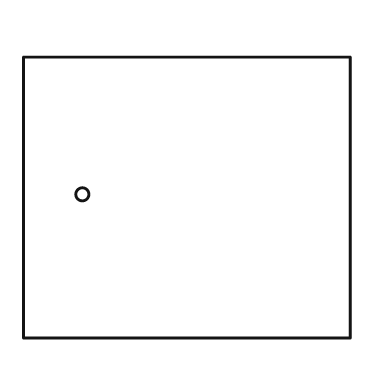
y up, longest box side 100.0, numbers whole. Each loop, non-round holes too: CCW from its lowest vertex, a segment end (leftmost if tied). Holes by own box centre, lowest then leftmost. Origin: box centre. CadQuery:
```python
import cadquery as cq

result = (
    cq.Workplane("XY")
    .moveTo(-50.0, -43.0)
    .lineTo(50.0, -43.0)
    .lineTo(50.0, 43.0)
    .lineTo(-50.0, 43.0)
    .close()
    .moveTo(-32.0, 1.0)
    .circle(2.0)
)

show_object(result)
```